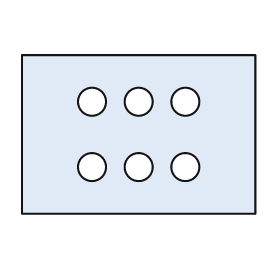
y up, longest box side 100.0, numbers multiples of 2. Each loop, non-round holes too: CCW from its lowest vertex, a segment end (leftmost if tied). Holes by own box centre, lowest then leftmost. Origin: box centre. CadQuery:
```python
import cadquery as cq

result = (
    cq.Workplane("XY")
    .moveTo(-50.0, -34.0)
    .lineTo(50.0, -34.0)
    .lineTo(50.0, 34.0)
    .lineTo(-50.0, 34.0)
    .close()
    .moveTo(-20.0, -14.0)
    .circle(6.0)
    .moveTo(0.0, -14.0)
    .circle(6.0)
    .moveTo(20.0, -14.0)
    .circle(6.0)
    .moveTo(-20.0, 14.0)
    .circle(6.0)
    .moveTo(0.0, 14.0)
    .circle(6.0)
    .moveTo(20.0, 14.0)
    .circle(6.0)
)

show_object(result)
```